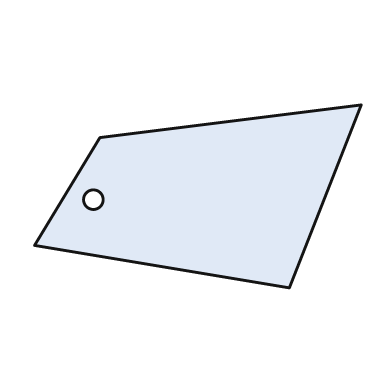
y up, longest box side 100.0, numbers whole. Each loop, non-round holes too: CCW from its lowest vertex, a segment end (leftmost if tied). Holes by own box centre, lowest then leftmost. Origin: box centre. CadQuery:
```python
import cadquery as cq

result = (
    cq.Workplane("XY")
    .moveTo(28.0, -28.0)
    .lineTo(50.0, 28.0)
    .lineTo(-30.0, 18.0)
    .lineTo(-50.0, -15.0)
    .close()
    .moveTo(-32.0, -1.0)
    .circle(3.0)
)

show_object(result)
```